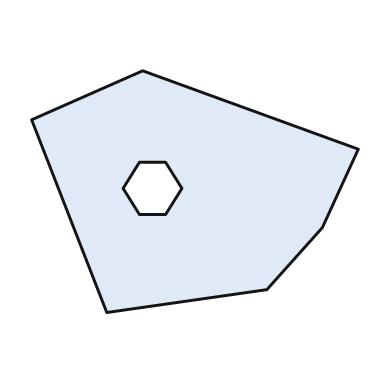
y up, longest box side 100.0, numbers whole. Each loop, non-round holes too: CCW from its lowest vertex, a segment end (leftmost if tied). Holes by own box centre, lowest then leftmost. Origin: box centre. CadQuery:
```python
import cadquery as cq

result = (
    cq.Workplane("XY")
    .moveTo(-27.0, -37.0)
    .lineTo(22.0, -30.0)
    .lineTo(39.0, -11.0)
    .lineTo(50.0, 13.0)
    .lineTo(-16.0, 37.0)
    .lineTo(-50.0, 22.0)
    .close()
    .moveTo(-17.0, -7.0)
    .lineTo(-9.0, -7.0)
    .lineTo(-4.0, 1.0)
    .lineTo(-9.0, 9.0)
    .lineTo(-17.0, 9.0)
    .lineTo(-22.0, 1.0)
    .close()
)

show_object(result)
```